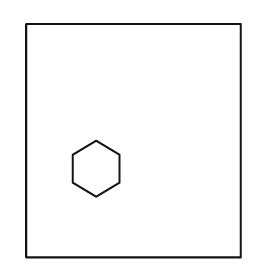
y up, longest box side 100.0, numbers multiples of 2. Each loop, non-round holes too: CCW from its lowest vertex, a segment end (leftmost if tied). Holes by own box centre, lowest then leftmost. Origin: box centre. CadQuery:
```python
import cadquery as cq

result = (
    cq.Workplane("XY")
    .moveTo(-46.0, -50.0)
    .lineTo(46.0, -50.0)
    .lineTo(46.0, 50.0)
    .lineTo(-46.0, 50.0)
    .close()
    .moveTo(-16.0, -24.0)
    .lineTo(-6.0, -18.0)
    .lineTo(-6.0, -6.0)
    .lineTo(-16.0, 0.0)
    .lineTo(-26.0, -6.0)
    .lineTo(-26.0, -18.0)
    .close()
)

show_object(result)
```